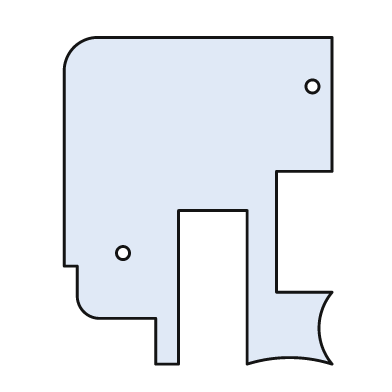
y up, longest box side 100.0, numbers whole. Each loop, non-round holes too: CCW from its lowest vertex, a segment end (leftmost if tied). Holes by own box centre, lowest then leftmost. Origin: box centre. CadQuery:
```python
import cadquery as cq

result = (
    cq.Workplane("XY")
    .moveTo(-13.0, -50.0)
    .lineTo(-6.0, -50.0)
    .lineTo(-6.0, -3.0)
    .lineTo(15.0, -3.0)
    .lineTo(15.0, -50.0)
    .threePointArc((28.0, -48.0), (41.0, -50.0))
    .threePointArc((37.0, -39.0), (41.0, -28.0))
    .lineTo(24.0, -28.0)
    .lineTo(24.0, 9.0)
    .lineTo(41.0, 9.0)
    .lineTo(41.0, 50.0)
    .lineTo(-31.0, 50.0)
    .threePointArc((-38.0, 47.0), (-41.0, 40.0))
    .lineTo(-41.0, -20.0)
    .lineTo(-37.0, -20.0)
    .lineTo(-37.0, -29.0)
    .threePointArc((-35.0, -34.0), (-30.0, -36.0))
    .lineTo(-13.0, -36.0)
    .close()
    .moveTo(-23.0, -16.0)
    .circle(2.0)
    .moveTo(35.0, 35.0)
    .circle(2.0)
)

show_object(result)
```